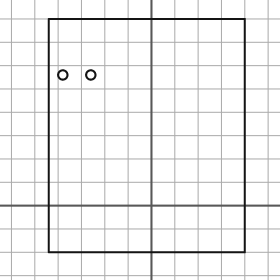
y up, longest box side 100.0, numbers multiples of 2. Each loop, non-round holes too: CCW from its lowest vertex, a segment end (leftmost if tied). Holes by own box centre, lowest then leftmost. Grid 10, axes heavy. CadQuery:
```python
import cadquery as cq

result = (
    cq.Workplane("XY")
    .moveTo(-44.0, -20.0)
    .lineTo(40.0, -20.0)
    .lineTo(40.0, 80.0)
    .lineTo(-44.0, 80.0)
    .close()
    .moveTo(-38.0, 56.0)
    .circle(2.0)
    .moveTo(-26.0, 56.0)
    .circle(2.0)
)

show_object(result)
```